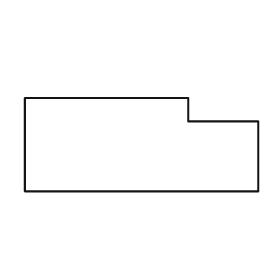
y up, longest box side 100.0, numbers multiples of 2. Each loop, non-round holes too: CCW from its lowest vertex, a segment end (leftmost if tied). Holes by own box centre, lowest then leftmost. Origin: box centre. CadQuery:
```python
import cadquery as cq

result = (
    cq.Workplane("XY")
    .moveTo(-50.0, -20.0)
    .lineTo(50.0, -20.0)
    .lineTo(50.0, 10.0)
    .lineTo(20.0, 10.0)
    .lineTo(20.0, 20.0)
    .lineTo(-50.0, 20.0)
    .close()
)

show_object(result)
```